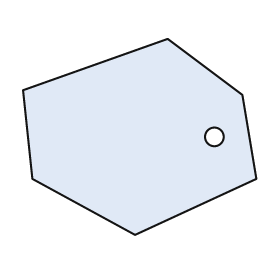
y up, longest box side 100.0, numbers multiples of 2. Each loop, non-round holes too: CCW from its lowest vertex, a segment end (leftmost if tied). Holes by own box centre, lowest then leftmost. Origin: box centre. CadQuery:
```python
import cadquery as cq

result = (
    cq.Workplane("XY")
    .moveTo(-2.0, -42.0)
    .lineTo(50.0, -18.0)
    .lineTo(44.0, 18.0)
    .lineTo(12.0, 42.0)
    .lineTo(-50.0, 20.0)
    .lineTo(-46.0, -18.0)
    .close()
    .moveTo(32.0, 0.0)
    .circle(4.0)
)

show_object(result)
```